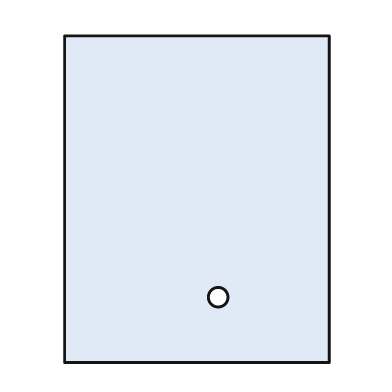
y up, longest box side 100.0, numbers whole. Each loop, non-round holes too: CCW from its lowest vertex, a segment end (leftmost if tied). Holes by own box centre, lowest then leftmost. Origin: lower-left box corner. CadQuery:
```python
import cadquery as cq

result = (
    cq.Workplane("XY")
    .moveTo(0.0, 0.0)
    .lineTo(81.0, 0.0)
    .lineTo(81.0, 100.0)
    .lineTo(0.0, 100.0)
    .close()
    .moveTo(47.0, 20.0)
    .circle(3.0)
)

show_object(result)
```